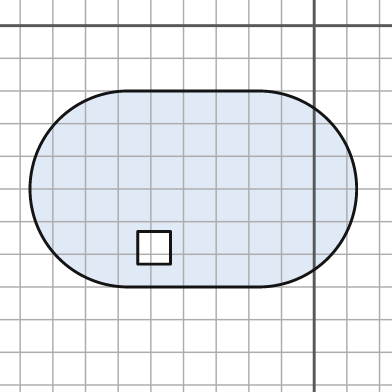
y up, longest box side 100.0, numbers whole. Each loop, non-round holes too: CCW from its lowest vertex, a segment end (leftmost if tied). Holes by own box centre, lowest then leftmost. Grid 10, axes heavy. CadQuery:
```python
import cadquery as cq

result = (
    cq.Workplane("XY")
    .moveTo(-57.0, -80.0)
    .lineTo(-17.0, -80.0)
    .threePointArc((13.0, -50.0), (-17.0, -20.0))
    .lineTo(-57.0, -20.0)
    .threePointArc((-87.0, -50.0), (-57.0, -80.0))
    .close()
    .moveTo(-54.0, -73.0)
    .lineTo(-44.0, -73.0)
    .lineTo(-44.0, -63.0)
    .lineTo(-54.0, -63.0)
    .close()
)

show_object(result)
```